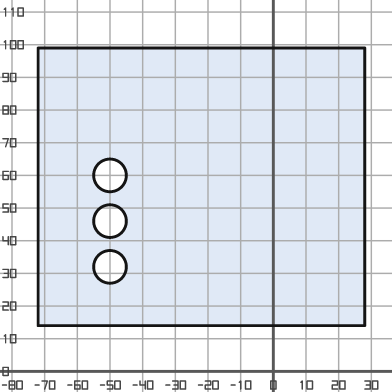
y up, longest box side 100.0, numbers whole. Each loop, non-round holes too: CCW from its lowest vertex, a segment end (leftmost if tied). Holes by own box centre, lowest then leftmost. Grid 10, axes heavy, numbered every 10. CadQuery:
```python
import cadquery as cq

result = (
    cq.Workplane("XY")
    .moveTo(-72.0, 14.0)
    .lineTo(28.0, 14.0)
    .lineTo(28.0, 99.0)
    .lineTo(-72.0, 99.0)
    .close()
    .moveTo(-50.0, 32.0)
    .circle(5.0)
    .moveTo(-50.0, 46.0)
    .circle(5.0)
    .moveTo(-50.0, 60.0)
    .circle(5.0)
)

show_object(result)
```